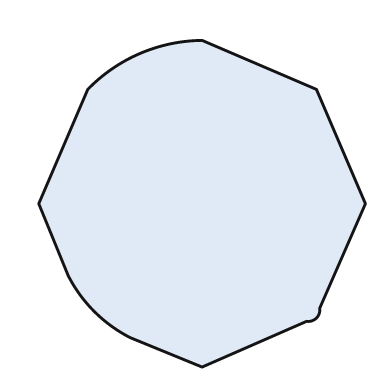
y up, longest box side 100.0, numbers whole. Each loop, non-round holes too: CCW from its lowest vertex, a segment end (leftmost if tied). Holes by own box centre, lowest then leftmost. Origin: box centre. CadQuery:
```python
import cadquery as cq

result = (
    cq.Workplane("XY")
    .moveTo(0.0, -50.0)
    .lineTo(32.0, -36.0)
    .threePointArc((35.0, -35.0), (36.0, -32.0))
    .lineTo(50.0, 0.0)
    .lineTo(35.0, 35.0)
    .lineTo(0.0, 50.0)
    .threePointArc((-19.0, 46.0), (-35.0, 35.0))
    .lineTo(-50.0, 0.0)
    .lineTo(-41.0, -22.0)
    .threePointArc((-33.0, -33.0), (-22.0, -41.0))
    .close()
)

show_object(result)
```